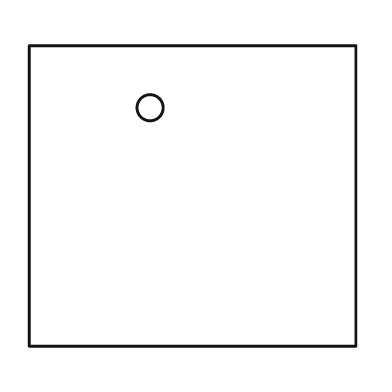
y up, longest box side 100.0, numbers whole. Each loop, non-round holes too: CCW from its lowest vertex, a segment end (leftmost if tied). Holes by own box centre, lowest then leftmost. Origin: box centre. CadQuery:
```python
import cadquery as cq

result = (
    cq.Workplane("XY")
    .moveTo(-50.0, -46.0)
    .lineTo(50.0, -46.0)
    .lineTo(50.0, 46.0)
    .lineTo(-50.0, 46.0)
    .close()
    .moveTo(-13.0, 27.0)
    .circle(4.0)
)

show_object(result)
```